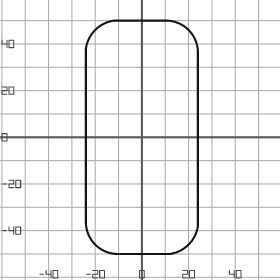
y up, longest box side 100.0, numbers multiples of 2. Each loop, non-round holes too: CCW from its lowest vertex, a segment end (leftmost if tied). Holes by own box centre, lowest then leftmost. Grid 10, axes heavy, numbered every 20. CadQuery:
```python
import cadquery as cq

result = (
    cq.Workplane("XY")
    .moveTo(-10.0, -50.0)
    .lineTo(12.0, -50.0)
    .threePointArc((20.0, -46.0), (24.0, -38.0))
    .lineTo(24.0, 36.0)
    .threePointArc((20.0, 46.0), (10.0, 50.0))
    .lineTo(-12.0, 50.0)
    .threePointArc((-20.0, 46.0), (-24.0, 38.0))
    .lineTo(-24.0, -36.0)
    .threePointArc((-20.0, -46.0), (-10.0, -50.0))
    .close()
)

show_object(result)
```